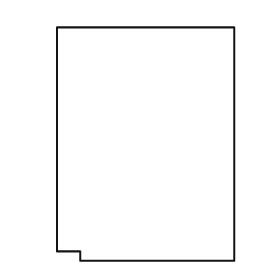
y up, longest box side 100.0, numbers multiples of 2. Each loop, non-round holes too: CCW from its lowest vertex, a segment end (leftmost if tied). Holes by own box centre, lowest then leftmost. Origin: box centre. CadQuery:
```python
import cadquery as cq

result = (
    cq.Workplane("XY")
    .moveTo(-28.0, -50.0)
    .lineTo(38.0, -50.0)
    .lineTo(38.0, 50.0)
    .lineTo(-38.0, 50.0)
    .lineTo(-38.0, -46.0)
    .lineTo(-28.0, -46.0)
    .close()
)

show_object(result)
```